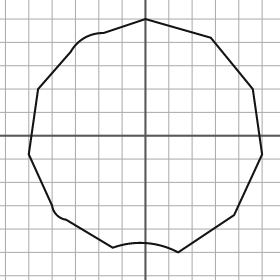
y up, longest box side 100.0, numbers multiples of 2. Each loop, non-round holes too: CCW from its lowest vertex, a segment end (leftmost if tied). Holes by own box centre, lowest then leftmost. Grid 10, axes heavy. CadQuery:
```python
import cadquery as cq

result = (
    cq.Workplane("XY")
    .moveTo(14.0, -50.0)
    .lineTo(38.0, -34.0)
    .lineTo(50.0, -8.0)
    .lineTo(46.0, 20.0)
    .lineTo(28.0, 42.0)
    .lineTo(0.0, 50.0)
    .lineTo(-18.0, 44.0)
    .threePointArc((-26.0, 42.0), (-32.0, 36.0))
    .lineTo(-46.0, 20.0)
    .lineTo(-50.0, -8.0)
    .lineTo(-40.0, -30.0)
    .threePointArc((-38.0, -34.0), (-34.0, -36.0))
    .lineTo(-14.0, -48.0)
    .threePointArc((0.0, -46.0), (14.0, -50.0))
    .close()
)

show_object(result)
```